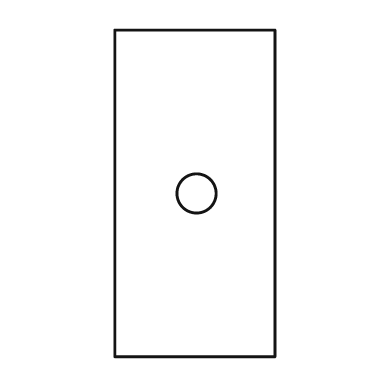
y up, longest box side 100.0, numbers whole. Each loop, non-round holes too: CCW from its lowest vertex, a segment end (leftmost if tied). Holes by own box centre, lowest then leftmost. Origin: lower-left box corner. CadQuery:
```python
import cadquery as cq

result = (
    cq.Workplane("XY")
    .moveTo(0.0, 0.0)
    .lineTo(49.0, 0.0)
    .lineTo(49.0, 100.0)
    .lineTo(0.0, 100.0)
    .close()
    .moveTo(25.0, 50.0)
    .circle(6.0)
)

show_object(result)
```